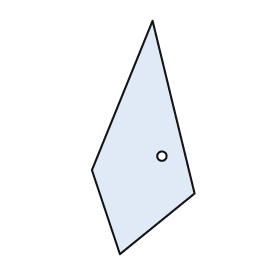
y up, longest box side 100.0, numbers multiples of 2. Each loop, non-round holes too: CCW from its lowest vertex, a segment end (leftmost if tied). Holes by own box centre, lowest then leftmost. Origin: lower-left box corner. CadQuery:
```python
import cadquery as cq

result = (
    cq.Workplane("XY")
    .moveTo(12.0, 0.0)
    .lineTo(44.0, 26.0)
    .lineTo(26.0, 100.0)
    .lineTo(0.0, 36.0)
    .close()
    .moveTo(30.0, 42.0)
    .circle(2.0)
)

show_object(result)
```